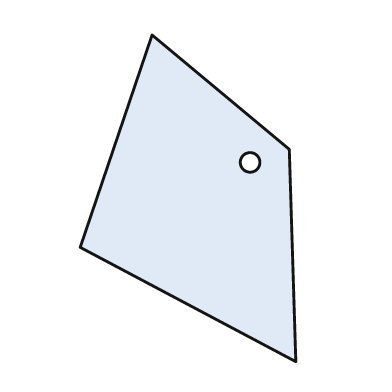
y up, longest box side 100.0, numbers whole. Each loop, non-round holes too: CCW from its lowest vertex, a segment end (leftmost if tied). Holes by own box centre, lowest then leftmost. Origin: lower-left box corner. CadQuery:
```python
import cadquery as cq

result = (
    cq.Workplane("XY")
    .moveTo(66.0, 0.0)
    .lineTo(64.0, 65.0)
    .lineTo(22.0, 100.0)
    .lineTo(0.0, 35.0)
    .close()
    .moveTo(52.0, 61.0)
    .circle(3.0)
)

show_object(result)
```